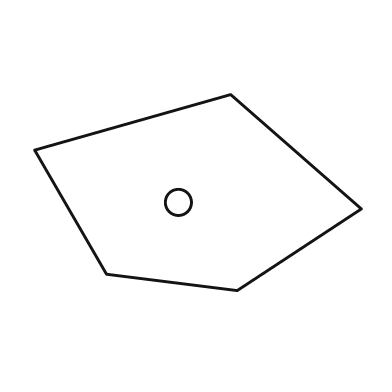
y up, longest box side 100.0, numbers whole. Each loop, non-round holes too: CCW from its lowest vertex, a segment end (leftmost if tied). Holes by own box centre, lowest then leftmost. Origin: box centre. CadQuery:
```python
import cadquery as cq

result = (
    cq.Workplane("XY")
    .moveTo(12.0, -30.0)
    .lineTo(50.0, -5.0)
    .lineTo(10.0, 30.0)
    .lineTo(-50.0, 13.0)
    .lineTo(-28.0, -25.0)
    .close()
    .moveTo(-6.0, -3.0)
    .circle(4.0)
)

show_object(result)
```